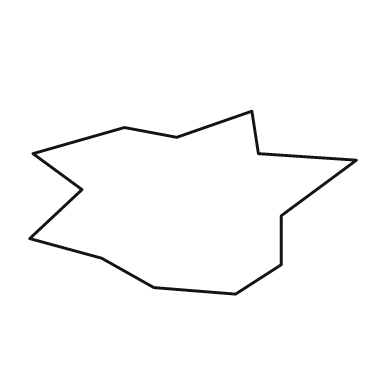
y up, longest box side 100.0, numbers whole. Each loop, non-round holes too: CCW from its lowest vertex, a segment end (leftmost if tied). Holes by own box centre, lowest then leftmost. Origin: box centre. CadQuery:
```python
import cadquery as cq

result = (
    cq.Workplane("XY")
    .moveTo(13.0, -28.0)
    .lineTo(27.0, -19.0)
    .lineTo(27.0, -4.0)
    .lineTo(50.0, 13.0)
    .lineTo(20.0, 15.0)
    .lineTo(18.0, 28.0)
    .lineTo(-5.0, 20.0)
    .lineTo(-21.0, 23.0)
    .lineTo(-49.0, 15.0)
    .lineTo(-34.0, 4.0)
    .lineTo(-50.0, -11.0)
    .lineTo(-28.0, -17.0)
    .lineTo(-12.0, -26.0)
    .close()
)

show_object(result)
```